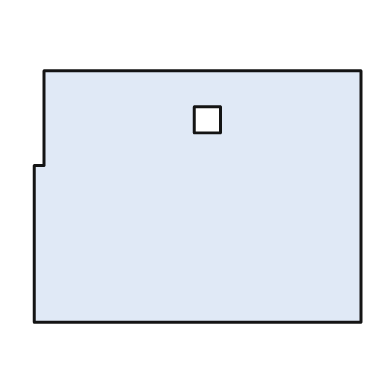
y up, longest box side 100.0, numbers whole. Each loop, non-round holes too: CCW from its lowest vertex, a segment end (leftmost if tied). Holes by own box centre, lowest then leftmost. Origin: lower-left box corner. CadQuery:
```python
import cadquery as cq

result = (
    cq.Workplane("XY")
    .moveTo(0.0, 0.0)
    .lineTo(100.0, 0.0)
    .lineTo(100.0, 77.0)
    .lineTo(3.0, 77.0)
    .lineTo(3.0, 48.0)
    .lineTo(0.0, 48.0)
    .close()
    .moveTo(49.0, 58.0)
    .lineTo(57.0, 58.0)
    .lineTo(57.0, 66.0)
    .lineTo(49.0, 66.0)
    .close()
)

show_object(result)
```